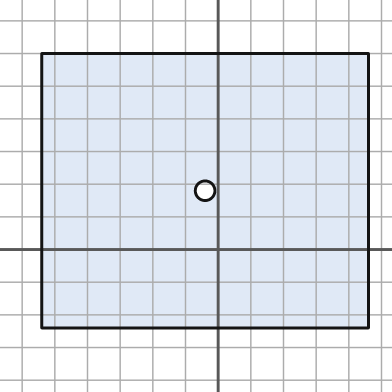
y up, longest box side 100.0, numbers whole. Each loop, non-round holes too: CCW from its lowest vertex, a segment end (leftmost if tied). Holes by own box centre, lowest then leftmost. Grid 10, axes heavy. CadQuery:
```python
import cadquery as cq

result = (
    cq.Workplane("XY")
    .moveTo(-54.0, -24.0)
    .lineTo(46.0, -24.0)
    .lineTo(46.0, 60.0)
    .lineTo(-54.0, 60.0)
    .close()
    .moveTo(-4.0, 18.0)
    .circle(3.0)
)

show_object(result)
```